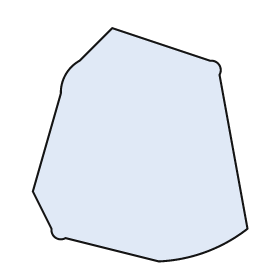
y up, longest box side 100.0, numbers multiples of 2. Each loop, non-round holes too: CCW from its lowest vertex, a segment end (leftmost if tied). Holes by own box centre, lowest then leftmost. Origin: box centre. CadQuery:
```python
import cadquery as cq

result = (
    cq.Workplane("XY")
    .moveTo(8.0, -50.0)
    .threePointArc((28.0, -46.0), (46.0, -36.0))
    .lineTo(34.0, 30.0)
    .threePointArc((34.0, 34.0), (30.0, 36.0))
    .lineTo(-12.0, 50.0)
    .lineTo(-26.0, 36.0)
    .threePointArc((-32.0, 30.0), (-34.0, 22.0))
    .lineTo(-46.0, -20.0)
    .lineTo(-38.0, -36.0)
    .threePointArc((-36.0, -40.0), (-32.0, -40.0))
    .close()
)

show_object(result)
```